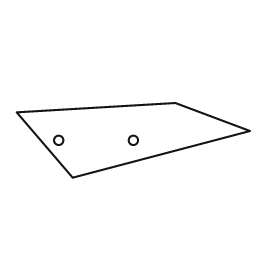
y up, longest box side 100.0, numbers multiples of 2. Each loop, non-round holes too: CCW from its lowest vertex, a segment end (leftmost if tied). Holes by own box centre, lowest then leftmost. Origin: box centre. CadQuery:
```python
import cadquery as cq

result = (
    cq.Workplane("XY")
    .moveTo(-26.0, -16.0)
    .lineTo(50.0, 4.0)
    .lineTo(18.0, 16.0)
    .lineTo(-50.0, 12.0)
    .close()
    .moveTo(-32.0, 0.0)
    .circle(2.0)
    .moveTo(0.0, 0.0)
    .circle(2.0)
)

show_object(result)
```